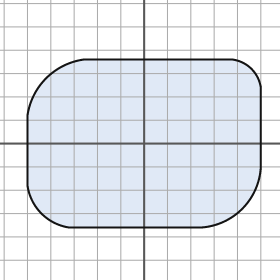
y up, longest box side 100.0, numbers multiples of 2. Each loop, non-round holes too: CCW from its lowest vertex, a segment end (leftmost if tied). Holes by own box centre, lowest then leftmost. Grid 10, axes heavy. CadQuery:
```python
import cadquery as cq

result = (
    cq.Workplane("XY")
    .moveTo(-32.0, -36.0)
    .lineTo(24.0, -36.0)
    .threePointArc((42.0, -28.0), (50.0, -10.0))
    .lineTo(50.0, 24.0)
    .threePointArc((46.0, 32.0), (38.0, 36.0))
    .lineTo(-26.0, 36.0)
    .threePointArc((-42.0, 28.0), (-50.0, 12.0))
    .lineTo(-50.0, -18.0)
    .threePointArc((-44.0, -30.0), (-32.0, -36.0))
    .close()
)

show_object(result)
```